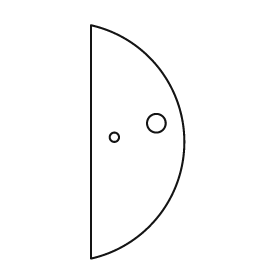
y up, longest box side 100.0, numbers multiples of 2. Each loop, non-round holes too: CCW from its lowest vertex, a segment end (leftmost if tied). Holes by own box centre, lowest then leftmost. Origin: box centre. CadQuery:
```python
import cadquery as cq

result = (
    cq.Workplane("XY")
    .moveTo(-20.0, -50.0)
    .threePointArc((20.0, 0.0), (-20.0, 50.0))
    .close()
    .moveTo(-10.0, 2.0)
    .circle(2.0)
    .moveTo(8.0, 8.0)
    .circle(4.0)
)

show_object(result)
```